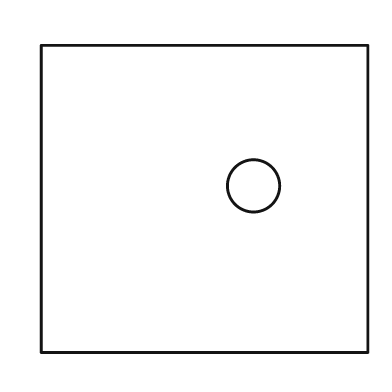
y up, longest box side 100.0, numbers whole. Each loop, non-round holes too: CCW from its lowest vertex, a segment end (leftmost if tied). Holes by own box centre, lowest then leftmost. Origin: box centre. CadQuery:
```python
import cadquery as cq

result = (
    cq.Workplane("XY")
    .moveTo(-50.0, -47.0)
    .lineTo(50.0, -47.0)
    .lineTo(50.0, 47.0)
    .lineTo(-50.0, 47.0)
    .close()
    .moveTo(15.0, 4.0)
    .circle(8.0)
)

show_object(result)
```